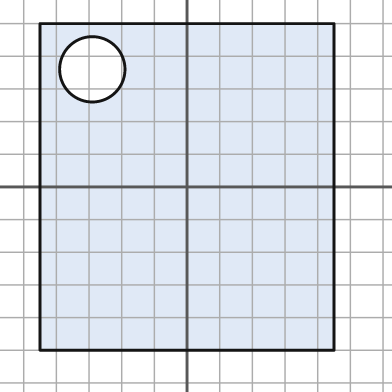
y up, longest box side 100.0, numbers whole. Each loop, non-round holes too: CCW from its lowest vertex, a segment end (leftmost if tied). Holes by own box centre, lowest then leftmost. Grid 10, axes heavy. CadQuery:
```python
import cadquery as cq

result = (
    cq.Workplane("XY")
    .moveTo(-45.0, -50.0)
    .lineTo(45.0, -50.0)
    .lineTo(45.0, 50.0)
    .lineTo(-45.0, 50.0)
    .close()
    .moveTo(-29.0, 36.0)
    .circle(10.0)
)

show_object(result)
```